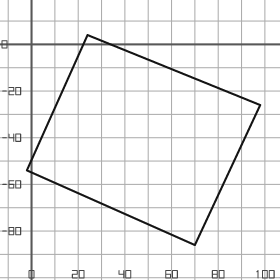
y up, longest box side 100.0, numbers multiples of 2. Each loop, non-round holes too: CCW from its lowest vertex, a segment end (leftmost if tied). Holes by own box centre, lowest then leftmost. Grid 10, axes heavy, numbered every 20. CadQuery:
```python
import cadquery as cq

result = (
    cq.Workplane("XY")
    .moveTo(70.0, -86.0)
    .lineTo(98.0, -26.0)
    .lineTo(24.0, 4.0)
    .lineTo(-2.0, -54.0)
    .close()
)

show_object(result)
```